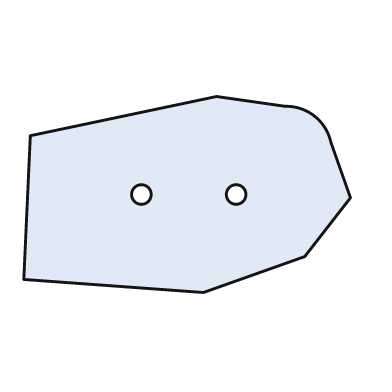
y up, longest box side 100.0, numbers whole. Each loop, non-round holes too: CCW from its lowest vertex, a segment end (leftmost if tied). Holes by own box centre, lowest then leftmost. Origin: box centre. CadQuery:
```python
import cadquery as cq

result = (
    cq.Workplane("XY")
    .moveTo(5.0, -30.0)
    .lineTo(36.0, -19.0)
    .lineTo(50.0, -1.0)
    .lineTo(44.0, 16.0)
    .threePointArc((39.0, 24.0), (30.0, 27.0))
    .lineTo(9.0, 30.0)
    .lineTo(-48.0, 18.0)
    .lineTo(-50.0, -26.0)
    .close()
    .moveTo(-14.0, 0.0)
    .circle(3.0)
    .moveTo(15.0, 0.0)
    .circle(3.0)
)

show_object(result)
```